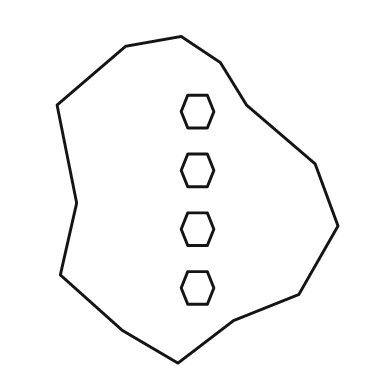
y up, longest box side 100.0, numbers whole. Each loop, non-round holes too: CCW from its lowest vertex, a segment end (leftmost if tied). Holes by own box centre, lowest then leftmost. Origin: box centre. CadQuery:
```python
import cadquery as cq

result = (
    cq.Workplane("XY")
    .moveTo(-6.0, -50.0)
    .lineTo(11.0, -37.0)
    .lineTo(31.0, -29.0)
    .lineTo(43.0, -8.0)
    .lineTo(36.0, 11.0)
    .lineTo(15.0, 29.0)
    .lineTo(7.0, 42.0)
    .lineTo(-5.0, 50.0)
    .lineTo(-22.0, 47.0)
    .lineTo(-43.0, 29.0)
    .lineTo(-37.0, -1.0)
    .lineTo(-42.0, -23.0)
    .lineTo(-23.0, -40.0)
    .close()
    .moveTo(-3.0, -32.0)
    .lineTo(3.0, -32.0)
    .lineTo(5.0, -27.0)
    .lineTo(3.0, -22.0)
    .lineTo(-3.0, -22.0)
    .lineTo(-5.0, -27.0)
    .close()
    .moveTo(-3.0, -14.0)
    .lineTo(3.0, -14.0)
    .lineTo(5.0, -9.0)
    .lineTo(3.0, -4.0)
    .lineTo(-3.0, -4.0)
    .lineTo(-5.0, -9.0)
    .close()
    .moveTo(-3.0, 4.0)
    .lineTo(3.0, 4.0)
    .lineTo(5.0, 9.0)
    .lineTo(3.0, 14.0)
    .lineTo(-3.0, 14.0)
    .lineTo(-5.0, 9.0)
    .close()
    .moveTo(-3.0, 22.0)
    .lineTo(3.0, 22.0)
    .lineTo(5.0, 27.0)
    .lineTo(3.0, 32.0)
    .lineTo(-3.0, 32.0)
    .lineTo(-5.0, 27.0)
    .close()
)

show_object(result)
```